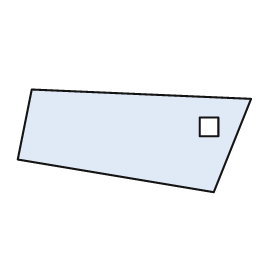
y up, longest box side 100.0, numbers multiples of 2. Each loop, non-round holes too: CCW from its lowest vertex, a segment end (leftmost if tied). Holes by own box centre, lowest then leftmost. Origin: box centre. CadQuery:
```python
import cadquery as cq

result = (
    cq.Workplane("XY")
    .moveTo(34.0, -22.0)
    .lineTo(50.0, 18.0)
    .lineTo(-44.0, 22.0)
    .lineTo(-50.0, -8.0)
    .close()
    .moveTo(28.0, 2.0)
    .lineTo(36.0, 2.0)
    .lineTo(36.0, 10.0)
    .lineTo(28.0, 10.0)
    .close()
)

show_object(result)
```